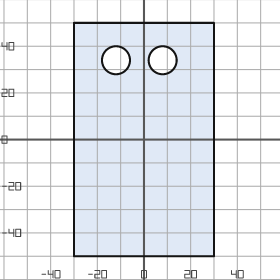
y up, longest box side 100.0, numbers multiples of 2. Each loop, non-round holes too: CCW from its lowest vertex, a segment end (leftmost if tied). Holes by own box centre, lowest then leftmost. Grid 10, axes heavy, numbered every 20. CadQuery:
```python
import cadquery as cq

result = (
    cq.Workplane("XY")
    .moveTo(-30.0, -50.0)
    .lineTo(30.0, -50.0)
    .lineTo(30.0, 50.0)
    .lineTo(-30.0, 50.0)
    .close()
    .moveTo(-12.0, 34.0)
    .circle(6.0)
    .moveTo(8.0, 34.0)
    .circle(6.0)
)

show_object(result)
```